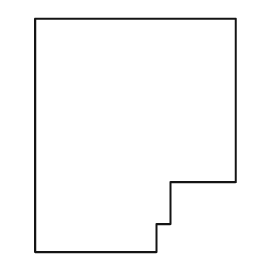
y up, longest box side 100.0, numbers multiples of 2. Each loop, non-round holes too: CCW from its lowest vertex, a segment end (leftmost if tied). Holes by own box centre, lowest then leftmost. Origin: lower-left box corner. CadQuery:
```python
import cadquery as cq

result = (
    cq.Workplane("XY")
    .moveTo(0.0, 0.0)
    .lineTo(52.0, 0.0)
    .lineTo(52.0, 12.0)
    .lineTo(58.0, 12.0)
    .lineTo(58.0, 30.0)
    .lineTo(86.0, 30.0)
    .lineTo(86.0, 100.0)
    .lineTo(0.0, 100.0)
    .close()
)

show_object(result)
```